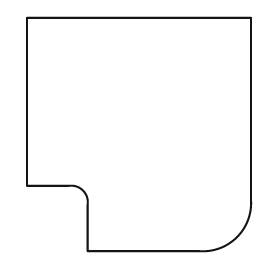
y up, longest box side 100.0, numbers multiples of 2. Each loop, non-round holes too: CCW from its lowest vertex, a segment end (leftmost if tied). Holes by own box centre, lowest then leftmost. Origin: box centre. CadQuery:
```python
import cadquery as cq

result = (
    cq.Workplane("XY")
    .moveTo(-22.0, -50.0)
    .lineTo(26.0, -50.0)
    .threePointArc((42.0, -44.0), (48.0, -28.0))
    .lineTo(48.0, 50.0)
    .lineTo(-48.0, 50.0)
    .lineTo(-48.0, -22.0)
    .lineTo(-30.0, -22.0)
    .threePointArc((-24.0, -24.0), (-22.0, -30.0))
    .close()
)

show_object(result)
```